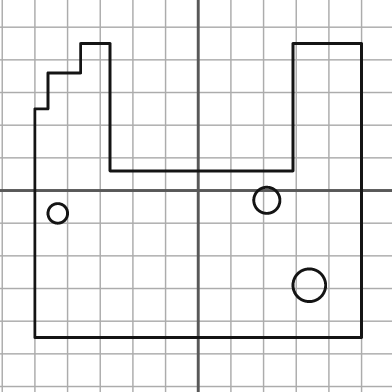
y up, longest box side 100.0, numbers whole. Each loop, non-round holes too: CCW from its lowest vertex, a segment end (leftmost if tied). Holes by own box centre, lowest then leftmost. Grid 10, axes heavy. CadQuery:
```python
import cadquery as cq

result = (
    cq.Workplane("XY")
    .moveTo(-50.0, -45.0)
    .lineTo(50.0, -45.0)
    .lineTo(50.0, 45.0)
    .lineTo(29.0, 45.0)
    .lineTo(29.0, 6.0)
    .lineTo(-27.0, 6.0)
    .lineTo(-27.0, 45.0)
    .lineTo(-36.0, 45.0)
    .lineTo(-36.0, 36.0)
    .lineTo(-46.0, 36.0)
    .lineTo(-46.0, 25.0)
    .lineTo(-50.0, 25.0)
    .close()
    .moveTo(34.0, -29.0)
    .circle(5.0)
    .moveTo(-43.0, -7.0)
    .circle(3.0)
    .moveTo(21.0, -3.0)
    .circle(4.0)
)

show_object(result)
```